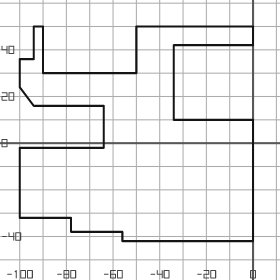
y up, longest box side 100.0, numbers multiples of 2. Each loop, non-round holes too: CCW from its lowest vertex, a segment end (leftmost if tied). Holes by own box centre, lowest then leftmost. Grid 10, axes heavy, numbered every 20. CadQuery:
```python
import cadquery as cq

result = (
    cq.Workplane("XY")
    .moveTo(-56.0, -42.0)
    .lineTo(0.0, -42.0)
    .lineTo(0.0, 10.0)
    .lineTo(-34.0, 10.0)
    .lineTo(-34.0, 42.0)
    .lineTo(0.0, 42.0)
    .lineTo(0.0, 50.0)
    .lineTo(-50.0, 50.0)
    .lineTo(-50.0, 30.0)
    .lineTo(-90.0, 30.0)
    .lineTo(-90.0, 50.0)
    .lineTo(-94.0, 50.0)
    .lineTo(-94.0, 36.0)
    .lineTo(-100.0, 36.0)
    .lineTo(-100.0, 24.0)
    .lineTo(-94.0, 16.0)
    .lineTo(-64.0, 16.0)
    .lineTo(-64.0, -2.0)
    .lineTo(-100.0, -2.0)
    .lineTo(-100.0, -32.0)
    .lineTo(-78.0, -32.0)
    .lineTo(-78.0, -38.0)
    .lineTo(-56.0, -38.0)
    .close()
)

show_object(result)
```